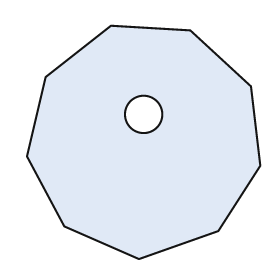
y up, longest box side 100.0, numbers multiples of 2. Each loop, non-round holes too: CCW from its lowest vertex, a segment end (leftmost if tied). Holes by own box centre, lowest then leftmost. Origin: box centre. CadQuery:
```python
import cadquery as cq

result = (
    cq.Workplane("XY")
    .moveTo(-2.0, -50.0)
    .lineTo(32.0, -38.0)
    .lineTo(50.0, -10.0)
    .lineTo(46.0, 24.0)
    .lineTo(20.0, 48.0)
    .lineTo(-14.0, 50.0)
    .lineTo(-42.0, 28.0)
    .lineTo(-50.0, -6.0)
    .lineTo(-34.0, -36.0)
    .close()
    .moveTo(0.0, 12.0)
    .circle(8.0)
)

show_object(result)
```